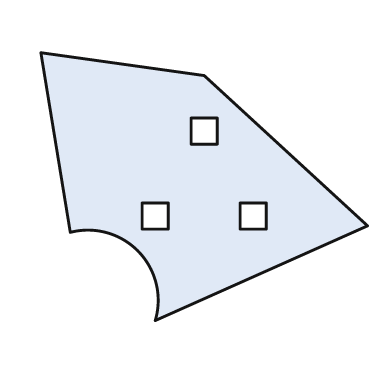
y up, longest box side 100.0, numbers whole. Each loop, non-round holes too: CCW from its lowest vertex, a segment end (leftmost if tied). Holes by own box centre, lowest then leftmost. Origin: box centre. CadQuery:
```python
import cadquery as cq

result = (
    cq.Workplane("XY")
    .moveTo(-15.0, -41.0)
    .lineTo(50.0, -12.0)
    .lineTo(0.0, 34.0)
    .lineTo(-50.0, 41.0)
    .lineTo(-41.0, -14.0)
    .threePointArc((-20.0, -20.0), (-15.0, -41.0))
    .close()
    .moveTo(-19.0, -13.0)
    .lineTo(-11.0, -13.0)
    .lineTo(-11.0, -5.0)
    .lineTo(-19.0, -5.0)
    .close()
    .moveTo(11.0, -13.0)
    .lineTo(19.0, -13.0)
    .lineTo(19.0, -5.0)
    .lineTo(11.0, -5.0)
    .close()
    .moveTo(-4.0, 13.0)
    .lineTo(4.0, 13.0)
    .lineTo(4.0, 21.0)
    .lineTo(-4.0, 21.0)
    .close()
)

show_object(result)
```